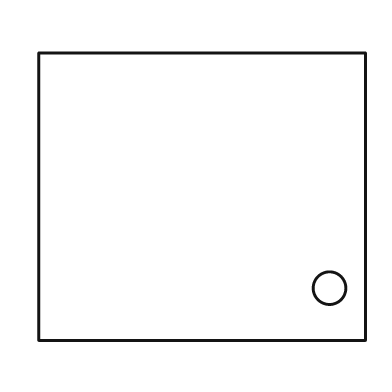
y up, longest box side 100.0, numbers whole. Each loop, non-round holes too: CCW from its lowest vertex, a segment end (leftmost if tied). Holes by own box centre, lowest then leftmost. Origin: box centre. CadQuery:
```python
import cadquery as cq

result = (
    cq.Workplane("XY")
    .moveTo(-50.0, -44.0)
    .lineTo(50.0, -44.0)
    .lineTo(50.0, 44.0)
    .lineTo(-50.0, 44.0)
    .close()
    .moveTo(39.0, -28.0)
    .circle(5.0)
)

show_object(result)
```